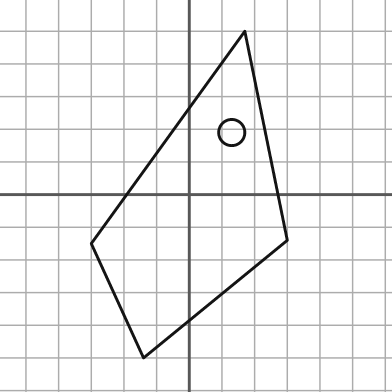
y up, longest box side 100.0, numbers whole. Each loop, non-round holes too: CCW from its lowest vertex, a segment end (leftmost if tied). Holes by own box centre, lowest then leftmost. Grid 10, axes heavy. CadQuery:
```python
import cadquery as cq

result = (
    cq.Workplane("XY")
    .moveTo(-14.0, -50.0)
    .lineTo(30.0, -14.0)
    .lineTo(17.0, 50.0)
    .lineTo(-30.0, -15.0)
    .close()
    .moveTo(13.0, 19.0)
    .circle(4.0)
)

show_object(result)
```